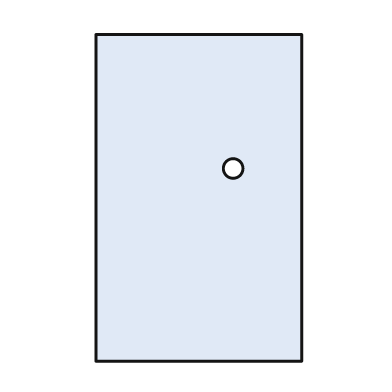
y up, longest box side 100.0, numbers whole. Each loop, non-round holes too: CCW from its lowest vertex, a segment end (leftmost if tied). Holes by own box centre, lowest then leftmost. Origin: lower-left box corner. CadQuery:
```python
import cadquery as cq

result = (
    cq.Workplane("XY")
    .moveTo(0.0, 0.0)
    .lineTo(63.0, 0.0)
    .lineTo(63.0, 100.0)
    .lineTo(0.0, 100.0)
    .close()
    .moveTo(42.0, 59.0)
    .circle(3.0)
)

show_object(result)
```